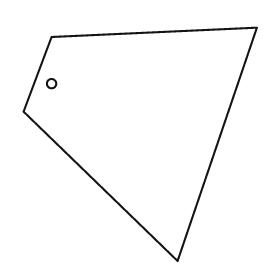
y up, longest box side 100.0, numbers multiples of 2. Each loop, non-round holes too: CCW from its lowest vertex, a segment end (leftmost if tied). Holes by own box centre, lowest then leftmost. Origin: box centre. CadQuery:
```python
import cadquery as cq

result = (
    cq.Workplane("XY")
    .moveTo(16.0, -50.0)
    .lineTo(50.0, 50.0)
    .lineTo(-38.0, 46.0)
    .lineTo(-50.0, 14.0)
    .close()
    .moveTo(-38.0, 26.0)
    .circle(2.0)
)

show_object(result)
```